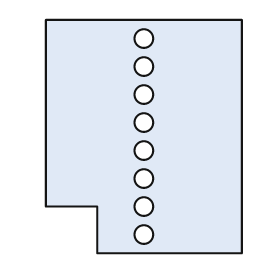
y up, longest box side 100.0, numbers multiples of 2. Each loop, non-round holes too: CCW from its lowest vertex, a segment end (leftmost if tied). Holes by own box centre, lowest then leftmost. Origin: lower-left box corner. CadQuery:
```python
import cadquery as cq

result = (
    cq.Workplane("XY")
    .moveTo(22.0, 0.0)
    .lineTo(84.0, 0.0)
    .lineTo(84.0, 100.0)
    .lineTo(0.0, 100.0)
    .lineTo(0.0, 20.0)
    .lineTo(22.0, 20.0)
    .close()
    .moveTo(42.0, 8.0)
    .circle(4.0)
    .moveTo(42.0, 20.0)
    .circle(4.0)
    .moveTo(42.0, 32.0)
    .circle(4.0)
    .moveTo(42.0, 44.0)
    .circle(4.0)
    .moveTo(42.0, 56.0)
    .circle(4.0)
    .moveTo(42.0, 68.0)
    .circle(4.0)
    .moveTo(42.0, 80.0)
    .circle(4.0)
    .moveTo(42.0, 92.0)
    .circle(4.0)
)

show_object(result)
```